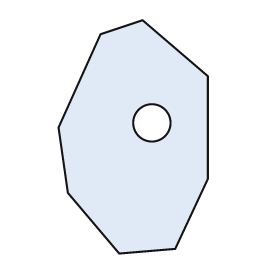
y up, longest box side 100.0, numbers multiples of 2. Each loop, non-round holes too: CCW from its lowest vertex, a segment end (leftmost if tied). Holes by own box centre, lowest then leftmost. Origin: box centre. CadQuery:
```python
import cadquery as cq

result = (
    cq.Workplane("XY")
    .moveTo(-6.0, -50.0)
    .lineTo(18.0, -48.0)
    .lineTo(32.0, -18.0)
    .lineTo(32.0, 26.0)
    .lineTo(4.0, 50.0)
    .lineTo(-14.0, 44.0)
    .lineTo(-32.0, 4.0)
    .lineTo(-28.0, -24.0)
    .close()
    .moveTo(8.0, 6.0)
    .circle(8.0)
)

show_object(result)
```